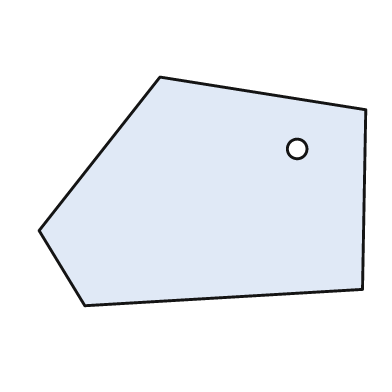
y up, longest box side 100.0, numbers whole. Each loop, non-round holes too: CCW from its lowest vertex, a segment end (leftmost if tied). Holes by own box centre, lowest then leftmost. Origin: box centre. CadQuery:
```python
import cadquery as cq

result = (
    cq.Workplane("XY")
    .moveTo(-36.0, -35.0)
    .lineTo(49.0, -30.0)
    .lineTo(50.0, 25.0)
    .lineTo(-13.0, 35.0)
    .lineTo(-50.0, -12.0)
    .close()
    .moveTo(29.0, 13.0)
    .circle(3.0)
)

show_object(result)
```